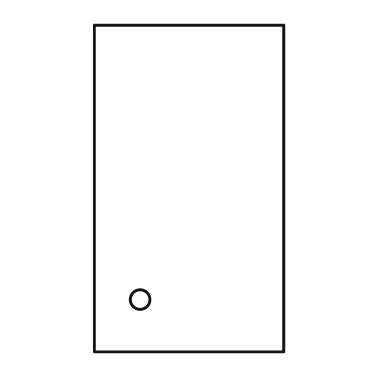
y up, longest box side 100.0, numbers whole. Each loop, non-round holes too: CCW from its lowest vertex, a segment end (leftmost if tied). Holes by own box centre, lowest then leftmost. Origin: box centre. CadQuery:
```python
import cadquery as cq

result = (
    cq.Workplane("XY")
    .moveTo(-29.0, -50.0)
    .lineTo(29.0, -50.0)
    .lineTo(29.0, 50.0)
    .lineTo(-29.0, 50.0)
    .close()
    .moveTo(-15.0, -34.0)
    .circle(3.0)
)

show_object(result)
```